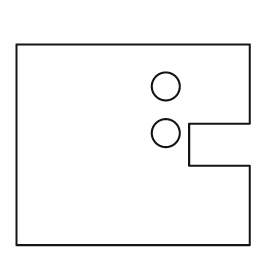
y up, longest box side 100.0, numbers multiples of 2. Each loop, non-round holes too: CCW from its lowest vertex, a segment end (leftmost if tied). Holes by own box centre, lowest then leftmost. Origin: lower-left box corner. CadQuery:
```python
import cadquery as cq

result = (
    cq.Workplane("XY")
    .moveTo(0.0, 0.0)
    .lineTo(100.0, 0.0)
    .lineTo(100.0, 34.0)
    .lineTo(74.0, 34.0)
    .lineTo(74.0, 52.0)
    .lineTo(100.0, 52.0)
    .lineTo(100.0, 86.0)
    .lineTo(0.0, 86.0)
    .close()
    .moveTo(64.0, 48.0)
    .circle(6.0)
    .moveTo(64.0, 68.0)
    .circle(6.0)
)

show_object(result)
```